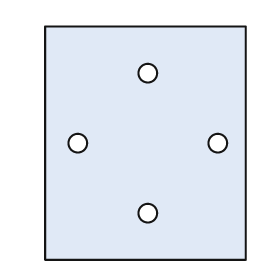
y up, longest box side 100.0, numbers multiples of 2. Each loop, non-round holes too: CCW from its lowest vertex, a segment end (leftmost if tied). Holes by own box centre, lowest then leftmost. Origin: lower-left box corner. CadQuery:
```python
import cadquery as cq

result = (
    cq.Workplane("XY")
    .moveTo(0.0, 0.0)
    .lineTo(86.0, 0.0)
    .lineTo(86.0, 100.0)
    .lineTo(0.0, 100.0)
    .close()
    .moveTo(44.0, 20.0)
    .circle(4.0)
    .moveTo(14.0, 50.0)
    .circle(4.0)
    .moveTo(74.0, 50.0)
    .circle(4.0)
    .moveTo(44.0, 80.0)
    .circle(4.0)
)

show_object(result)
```